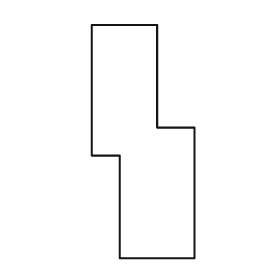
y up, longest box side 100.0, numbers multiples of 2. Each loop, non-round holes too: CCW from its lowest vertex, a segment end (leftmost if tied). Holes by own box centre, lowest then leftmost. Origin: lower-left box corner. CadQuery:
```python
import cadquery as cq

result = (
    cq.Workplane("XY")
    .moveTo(12.0, 0.0)
    .lineTo(44.0, 0.0)
    .lineTo(44.0, 56.0)
    .lineTo(28.0, 56.0)
    .lineTo(28.0, 100.0)
    .lineTo(0.0, 100.0)
    .lineTo(0.0, 44.0)
    .lineTo(12.0, 44.0)
    .close()
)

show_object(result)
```